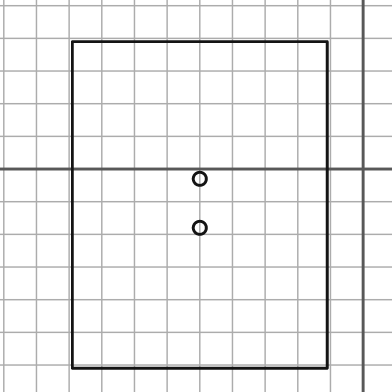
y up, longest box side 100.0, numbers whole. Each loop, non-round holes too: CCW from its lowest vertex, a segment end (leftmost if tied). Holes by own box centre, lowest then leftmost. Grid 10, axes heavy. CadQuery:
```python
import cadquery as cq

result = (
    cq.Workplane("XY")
    .moveTo(-89.0, -61.0)
    .lineTo(-11.0, -61.0)
    .lineTo(-11.0, 39.0)
    .lineTo(-89.0, 39.0)
    .close()
    .moveTo(-50.0, -18.0)
    .circle(2.0)
    .moveTo(-50.0, -3.0)
    .circle(2.0)
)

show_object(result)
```